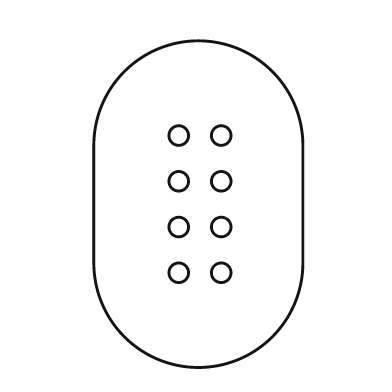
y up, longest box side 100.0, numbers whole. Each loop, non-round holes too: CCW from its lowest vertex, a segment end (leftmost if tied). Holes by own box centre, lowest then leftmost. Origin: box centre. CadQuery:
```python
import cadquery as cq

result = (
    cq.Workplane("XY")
    .moveTo(-32.0, -18.0)
    .threePointArc((0.0, -50.0), (32.0, -18.0))
    .lineTo(32.0, 18.0)
    .threePointArc((0.0, 50.0), (-32.0, 18.0))
    .close()
    .moveTo(-6.0, -21.0)
    .circle(3.0)
    .moveTo(7.0, -21.0)
    .circle(3.0)
    .moveTo(-6.0, -7.0)
    .circle(3.0)
    .moveTo(7.0, -7.0)
    .circle(3.0)
    .moveTo(-6.0, 7.0)
    .circle(3.0)
    .moveTo(7.0, 7.0)
    .circle(3.0)
    .moveTo(-6.0, 21.0)
    .circle(3.0)
    .moveTo(7.0, 21.0)
    .circle(3.0)
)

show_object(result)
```